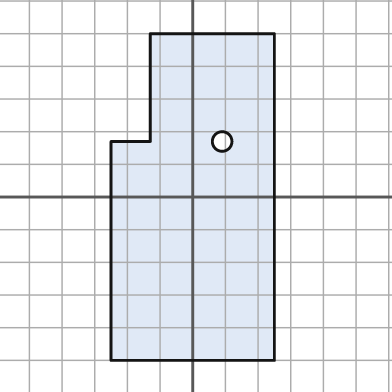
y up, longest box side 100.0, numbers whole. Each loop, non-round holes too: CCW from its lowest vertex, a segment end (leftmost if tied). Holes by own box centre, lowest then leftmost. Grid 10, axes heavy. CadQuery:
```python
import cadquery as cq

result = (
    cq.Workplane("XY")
    .moveTo(-25.0, -50.0)
    .lineTo(25.0, -50.0)
    .lineTo(25.0, 50.0)
    .lineTo(-13.0, 50.0)
    .lineTo(-13.0, 17.0)
    .lineTo(-25.0, 17.0)
    .close()
    .moveTo(9.0, 17.0)
    .circle(3.0)
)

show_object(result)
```